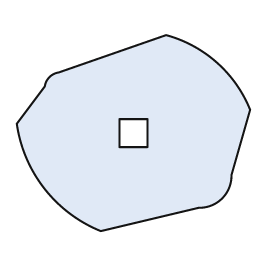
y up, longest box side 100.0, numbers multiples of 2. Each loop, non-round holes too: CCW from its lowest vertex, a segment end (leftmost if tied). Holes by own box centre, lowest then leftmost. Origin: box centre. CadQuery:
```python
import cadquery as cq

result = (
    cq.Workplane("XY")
    .moveTo(-14.0, -42.0)
    .lineTo(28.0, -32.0)
    .threePointArc((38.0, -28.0), (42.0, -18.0))
    .lineTo(50.0, 10.0)
    .threePointArc((36.0, 30.0), (14.0, 42.0))
    .lineTo(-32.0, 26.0)
    .threePointArc((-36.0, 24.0), (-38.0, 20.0))
    .lineTo(-50.0, 4.0)
    .threePointArc((-38.0, -24.0), (-14.0, -42.0))
    .close()
    .moveTo(-6.0, -6.0)
    .lineTo(6.0, -6.0)
    .lineTo(6.0, 6.0)
    .lineTo(-6.0, 6.0)
    .close()
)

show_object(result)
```